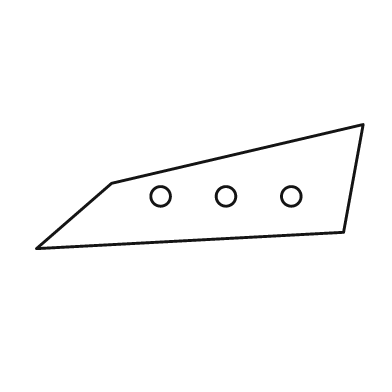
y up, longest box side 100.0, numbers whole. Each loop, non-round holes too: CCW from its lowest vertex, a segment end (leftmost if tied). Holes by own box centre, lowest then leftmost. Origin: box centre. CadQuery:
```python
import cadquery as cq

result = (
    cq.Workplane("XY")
    .moveTo(-50.0, -19.0)
    .lineTo(44.0, -14.0)
    .lineTo(50.0, 19.0)
    .lineTo(-27.0, 1.0)
    .close()
    .moveTo(-12.0, -3.0)
    .circle(3.0)
    .moveTo(8.0, -3.0)
    .circle(3.0)
    .moveTo(28.0, -3.0)
    .circle(3.0)
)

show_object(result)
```